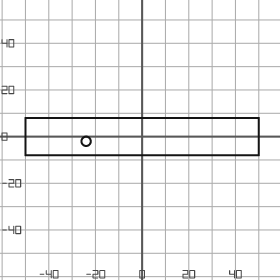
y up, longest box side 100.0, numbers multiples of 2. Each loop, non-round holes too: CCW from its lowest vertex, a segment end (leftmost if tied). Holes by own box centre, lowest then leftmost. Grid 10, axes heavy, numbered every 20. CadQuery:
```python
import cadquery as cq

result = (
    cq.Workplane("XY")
    .moveTo(-50.0, -8.0)
    .lineTo(50.0, -8.0)
    .lineTo(50.0, 8.0)
    .lineTo(-50.0, 8.0)
    .close()
    .moveTo(-24.0, -2.0)
    .circle(2.0)
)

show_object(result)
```